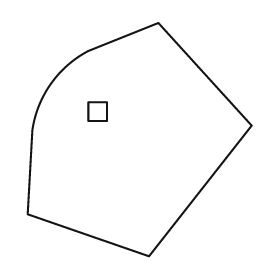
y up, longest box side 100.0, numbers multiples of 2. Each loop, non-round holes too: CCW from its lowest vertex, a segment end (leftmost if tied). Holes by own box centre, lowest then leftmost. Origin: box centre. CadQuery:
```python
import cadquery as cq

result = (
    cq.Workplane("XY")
    .moveTo(4.0, -50.0)
    .lineTo(48.0, 6.0)
    .lineTo(8.0, 50.0)
    .lineTo(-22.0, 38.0)
    .threePointArc((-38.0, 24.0), (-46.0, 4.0))
    .lineTo(-48.0, -32.0)
    .close()
    .moveTo(-22.0, 8.0)
    .lineTo(-14.0, 8.0)
    .lineTo(-14.0, 16.0)
    .lineTo(-22.0, 16.0)
    .close()
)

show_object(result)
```